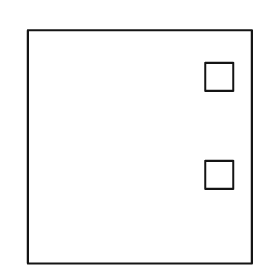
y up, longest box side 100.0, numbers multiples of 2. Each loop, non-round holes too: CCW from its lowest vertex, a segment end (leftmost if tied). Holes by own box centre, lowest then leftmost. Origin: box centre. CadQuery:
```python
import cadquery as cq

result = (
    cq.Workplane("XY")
    .moveTo(-48.0, -50.0)
    .lineTo(48.0, -50.0)
    .lineTo(48.0, 50.0)
    .lineTo(-48.0, 50.0)
    .close()
    .moveTo(28.0, -18.0)
    .lineTo(40.0, -18.0)
    .lineTo(40.0, -6.0)
    .lineTo(28.0, -6.0)
    .close()
    .moveTo(28.0, 24.0)
    .lineTo(40.0, 24.0)
    .lineTo(40.0, 36.0)
    .lineTo(28.0, 36.0)
    .close()
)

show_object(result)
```